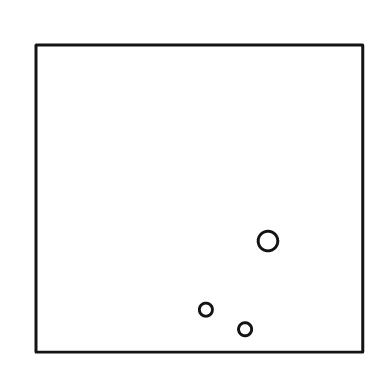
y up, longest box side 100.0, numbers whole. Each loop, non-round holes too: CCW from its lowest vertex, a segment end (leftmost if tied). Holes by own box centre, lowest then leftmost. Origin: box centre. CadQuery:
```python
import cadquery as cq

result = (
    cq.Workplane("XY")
    .moveTo(-50.0, -47.0)
    .lineTo(50.0, -47.0)
    .lineTo(50.0, 47.0)
    .lineTo(-50.0, 47.0)
    .close()
    .moveTo(14.0, -40.0)
    .circle(2.0)
    .moveTo(2.0, -34.0)
    .circle(2.0)
    .moveTo(21.0, -13.0)
    .circle(3.0)
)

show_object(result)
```